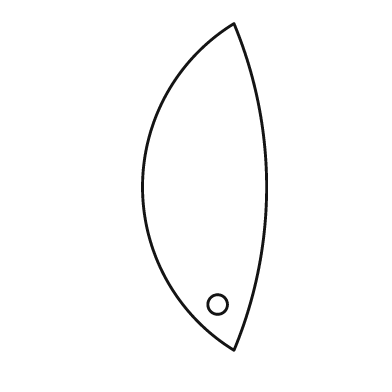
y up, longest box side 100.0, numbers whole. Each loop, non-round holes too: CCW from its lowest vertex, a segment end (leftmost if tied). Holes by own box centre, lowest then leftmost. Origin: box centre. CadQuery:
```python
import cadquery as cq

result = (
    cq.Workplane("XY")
    .moveTo(9.0, -50.0)
    .threePointArc((19.0, 0.0), (9.0, 50.0))
    .threePointArc((-19.0, 0.0), (9.0, -50.0))
    .close()
    .moveTo(4.0, -36.0)
    .circle(3.0)
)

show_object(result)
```